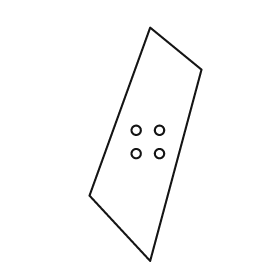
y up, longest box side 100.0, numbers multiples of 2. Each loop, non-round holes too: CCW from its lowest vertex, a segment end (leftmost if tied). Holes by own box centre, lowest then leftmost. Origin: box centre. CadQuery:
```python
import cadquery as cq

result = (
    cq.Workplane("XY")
    .moveTo(2.0, -50.0)
    .lineTo(24.0, 32.0)
    .lineTo(2.0, 50.0)
    .lineTo(-24.0, -22.0)
    .close()
    .moveTo(-4.0, -4.0)
    .circle(2.0)
    .moveTo(6.0, -4.0)
    .circle(2.0)
    .moveTo(-4.0, 6.0)
    .circle(2.0)
    .moveTo(6.0, 6.0)
    .circle(2.0)
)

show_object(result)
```